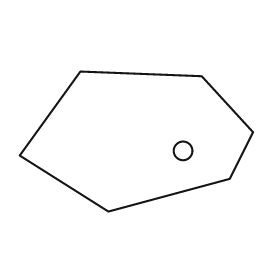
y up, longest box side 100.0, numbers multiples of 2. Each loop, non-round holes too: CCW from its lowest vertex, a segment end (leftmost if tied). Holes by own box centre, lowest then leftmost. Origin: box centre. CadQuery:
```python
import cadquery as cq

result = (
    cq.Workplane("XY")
    .moveTo(-12.0, -30.0)
    .lineTo(40.0, -16.0)
    .lineTo(50.0, 4.0)
    .lineTo(28.0, 28.0)
    .lineTo(-24.0, 30.0)
    .lineTo(-50.0, -6.0)
    .close()
    .moveTo(20.0, -4.0)
    .circle(4.0)
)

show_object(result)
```